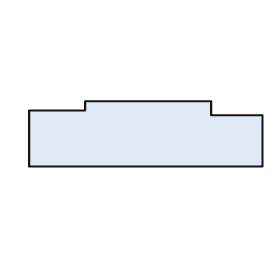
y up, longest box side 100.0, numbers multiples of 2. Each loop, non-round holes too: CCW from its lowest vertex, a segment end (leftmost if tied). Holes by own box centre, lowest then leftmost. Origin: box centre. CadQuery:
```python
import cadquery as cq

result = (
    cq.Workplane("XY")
    .moveTo(-50.0, -14.0)
    .lineTo(50.0, -14.0)
    .lineTo(50.0, 8.0)
    .lineTo(28.0, 8.0)
    .lineTo(28.0, 14.0)
    .lineTo(-26.0, 14.0)
    .lineTo(-26.0, 10.0)
    .lineTo(-50.0, 10.0)
    .close()
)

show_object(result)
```